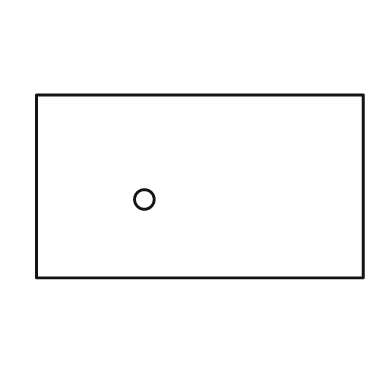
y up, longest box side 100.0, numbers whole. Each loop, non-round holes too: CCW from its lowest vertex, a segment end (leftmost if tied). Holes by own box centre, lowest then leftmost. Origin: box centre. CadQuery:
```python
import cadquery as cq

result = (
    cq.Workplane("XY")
    .moveTo(-50.0, -28.0)
    .lineTo(50.0, -28.0)
    .lineTo(50.0, 28.0)
    .lineTo(-50.0, 28.0)
    .close()
    .moveTo(-17.0, -4.0)
    .circle(3.0)
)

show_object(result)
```